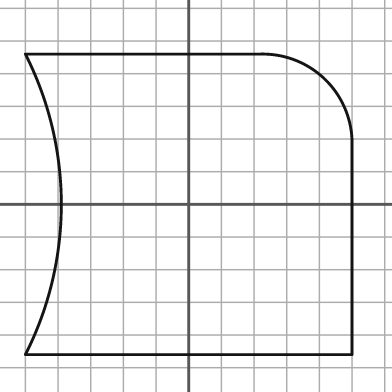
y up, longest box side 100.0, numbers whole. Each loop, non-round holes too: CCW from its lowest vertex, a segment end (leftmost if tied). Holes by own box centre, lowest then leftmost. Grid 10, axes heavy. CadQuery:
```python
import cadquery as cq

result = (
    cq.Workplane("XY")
    .moveTo(-50.0, -46.0)
    .lineTo(50.0, -46.0)
    .lineTo(50.0, 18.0)
    .threePointArc((42.0, 38.0), (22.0, 46.0))
    .lineTo(-50.0, 46.0)
    .threePointArc((-39.0, 0.0), (-50.0, -46.0))
    .close()
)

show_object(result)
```